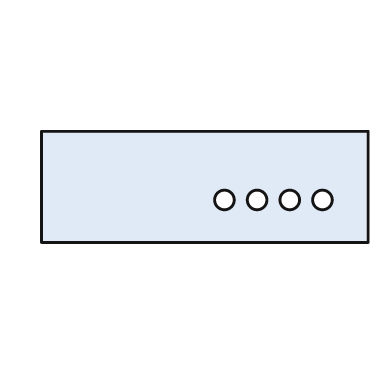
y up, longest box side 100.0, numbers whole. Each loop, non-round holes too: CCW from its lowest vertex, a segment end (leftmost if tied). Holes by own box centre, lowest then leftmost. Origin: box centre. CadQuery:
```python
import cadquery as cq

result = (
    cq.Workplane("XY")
    .moveTo(-50.0, -17.0)
    .lineTo(50.0, -17.0)
    .lineTo(50.0, 17.0)
    .lineTo(-50.0, 17.0)
    .close()
    .moveTo(6.0, -4.0)
    .circle(3.0)
    .moveTo(16.0, -4.0)
    .circle(3.0)
    .moveTo(26.0, -4.0)
    .circle(3.0)
    .moveTo(36.0, -4.0)
    .circle(3.0)
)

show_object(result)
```